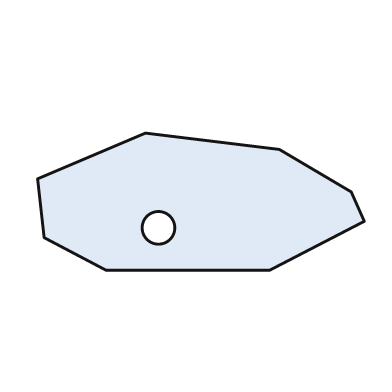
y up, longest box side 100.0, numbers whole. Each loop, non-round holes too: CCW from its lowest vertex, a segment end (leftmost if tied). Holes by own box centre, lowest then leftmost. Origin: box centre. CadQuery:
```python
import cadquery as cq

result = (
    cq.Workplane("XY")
    .moveTo(-29.0, -21.0)
    .lineTo(21.0, -21.0)
    .lineTo(50.0, -6.0)
    .lineTo(46.0, 3.0)
    .lineTo(24.0, 16.0)
    .lineTo(-17.0, 21.0)
    .lineTo(-50.0, 7.0)
    .lineTo(-48.0, -11.0)
    .close()
    .moveTo(-13.0, -8.0)
    .circle(5.0)
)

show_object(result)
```